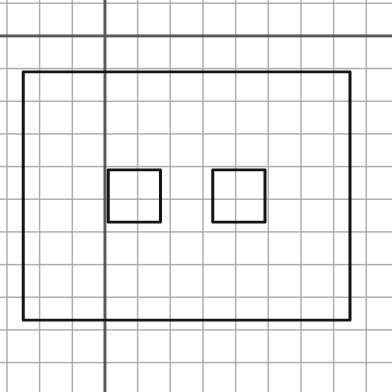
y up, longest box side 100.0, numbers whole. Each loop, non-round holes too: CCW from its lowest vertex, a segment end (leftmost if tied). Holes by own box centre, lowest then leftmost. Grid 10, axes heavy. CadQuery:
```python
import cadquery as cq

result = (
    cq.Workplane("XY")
    .moveTo(-25.0, -87.0)
    .lineTo(75.0, -87.0)
    .lineTo(75.0, -11.0)
    .lineTo(-25.0, -11.0)
    .close()
    .moveTo(1.0, -57.0)
    .lineTo(17.0, -57.0)
    .lineTo(17.0, -41.0)
    .lineTo(1.0, -41.0)
    .close()
    .moveTo(33.0, -57.0)
    .lineTo(49.0, -57.0)
    .lineTo(49.0, -41.0)
    .lineTo(33.0, -41.0)
    .close()
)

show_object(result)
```